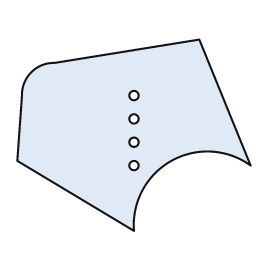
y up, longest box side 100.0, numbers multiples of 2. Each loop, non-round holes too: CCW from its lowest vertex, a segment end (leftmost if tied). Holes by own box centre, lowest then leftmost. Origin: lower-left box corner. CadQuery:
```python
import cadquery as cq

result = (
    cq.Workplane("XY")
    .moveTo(50.0, 0.0)
    .threePointArc((66.0, 30.0), (100.0, 28.0))
    .lineTo(78.0, 82.0)
    .lineTo(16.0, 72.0)
    .threePointArc((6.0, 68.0), (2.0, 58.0))
    .lineTo(0.0, 30.0)
    .close()
    .moveTo(50.0, 28.0)
    .circle(2.0)
    .moveTo(50.0, 38.0)
    .circle(2.0)
    .moveTo(50.0, 48.0)
    .circle(2.0)
    .moveTo(50.0, 58.0)
    .circle(2.0)
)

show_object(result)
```